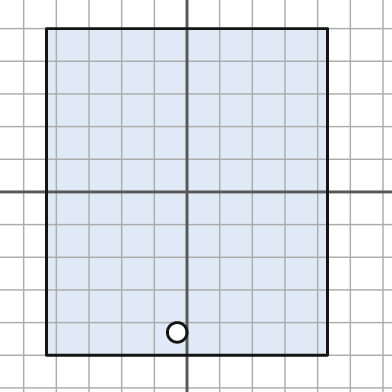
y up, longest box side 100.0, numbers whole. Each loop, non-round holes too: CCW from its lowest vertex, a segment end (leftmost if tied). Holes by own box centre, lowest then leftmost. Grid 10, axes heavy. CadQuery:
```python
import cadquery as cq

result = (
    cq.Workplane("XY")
    .moveTo(-43.0, -50.0)
    .lineTo(43.0, -50.0)
    .lineTo(43.0, 50.0)
    .lineTo(-43.0, 50.0)
    .close()
    .moveTo(-3.0, -43.0)
    .circle(3.0)
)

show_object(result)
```